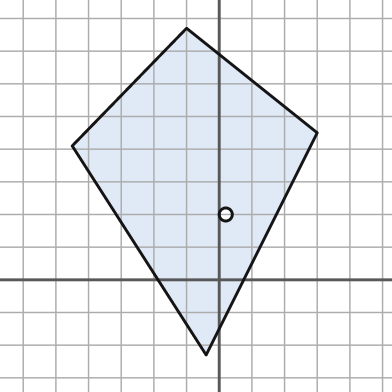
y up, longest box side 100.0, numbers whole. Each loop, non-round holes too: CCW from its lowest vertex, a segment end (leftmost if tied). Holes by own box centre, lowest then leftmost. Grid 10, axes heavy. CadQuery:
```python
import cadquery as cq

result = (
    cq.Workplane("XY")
    .moveTo(-4.0, -23.0)
    .lineTo(30.0, 45.0)
    .lineTo(-10.0, 77.0)
    .lineTo(-45.0, 41.0)
    .close()
    .moveTo(2.0, 20.0)
    .circle(2.0)
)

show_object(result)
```